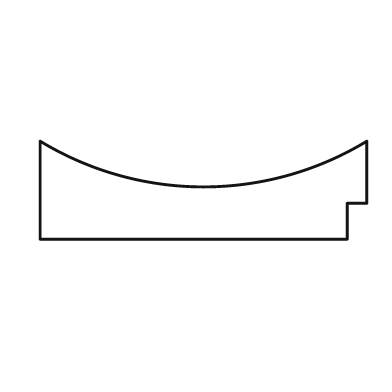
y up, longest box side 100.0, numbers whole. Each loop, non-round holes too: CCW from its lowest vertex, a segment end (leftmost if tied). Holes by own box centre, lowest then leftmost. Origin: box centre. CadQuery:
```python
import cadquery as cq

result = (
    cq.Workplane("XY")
    .moveTo(-50.0, -15.0)
    .lineTo(44.0, -15.0)
    .lineTo(44.0, -4.0)
    .lineTo(50.0, -4.0)
    .lineTo(50.0, 15.0)
    .threePointArc((0.0, 1.0), (-50.0, 15.0))
    .close()
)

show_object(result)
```